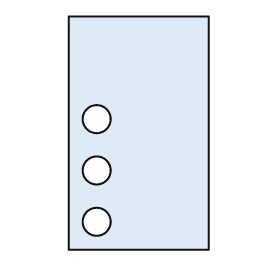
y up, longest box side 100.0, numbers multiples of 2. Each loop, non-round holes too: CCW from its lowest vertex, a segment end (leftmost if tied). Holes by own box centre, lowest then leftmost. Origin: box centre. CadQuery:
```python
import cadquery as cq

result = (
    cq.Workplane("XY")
    .moveTo(-30.0, -50.0)
    .lineTo(30.0, -50.0)
    .lineTo(30.0, 50.0)
    .lineTo(-30.0, 50.0)
    .close()
    .moveTo(-18.0, -38.0)
    .circle(6.0)
    .moveTo(-18.0, -16.0)
    .circle(6.0)
    .moveTo(-18.0, 6.0)
    .circle(6.0)
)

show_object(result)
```